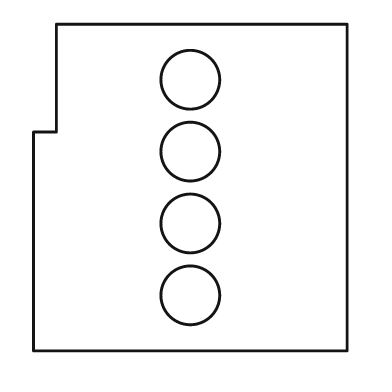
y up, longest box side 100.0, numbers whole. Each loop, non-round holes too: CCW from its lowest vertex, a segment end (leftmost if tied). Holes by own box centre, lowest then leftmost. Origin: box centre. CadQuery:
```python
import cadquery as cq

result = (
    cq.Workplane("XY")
    .moveTo(-48.0, -50.0)
    .lineTo(48.0, -50.0)
    .lineTo(48.0, 50.0)
    .lineTo(-41.0, 50.0)
    .lineTo(-41.0, 17.0)
    .lineTo(-48.0, 17.0)
    .close()
    .moveTo(0.0, -33.0)
    .circle(9.0)
    .moveTo(0.0, -11.0)
    .circle(9.0)
    .moveTo(0.0, 11.0)
    .circle(9.0)
    .moveTo(0.0, 33.0)
    .circle(9.0)
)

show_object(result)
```